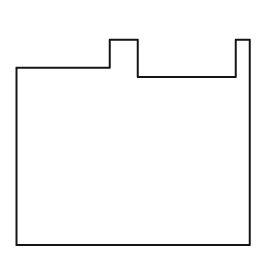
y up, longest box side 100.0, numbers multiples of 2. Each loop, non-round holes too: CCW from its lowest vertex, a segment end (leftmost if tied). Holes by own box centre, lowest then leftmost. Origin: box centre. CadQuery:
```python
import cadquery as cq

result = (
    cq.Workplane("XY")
    .moveTo(-50.0, -44.0)
    .lineTo(50.0, -44.0)
    .lineTo(50.0, 44.0)
    .lineTo(44.0, 44.0)
    .lineTo(44.0, 28.0)
    .lineTo(2.0, 28.0)
    .lineTo(2.0, 44.0)
    .lineTo(-10.0, 44.0)
    .lineTo(-10.0, 32.0)
    .lineTo(-50.0, 32.0)
    .close()
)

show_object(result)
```